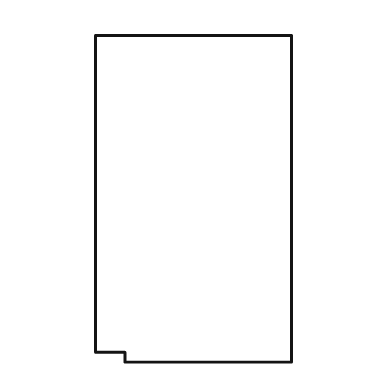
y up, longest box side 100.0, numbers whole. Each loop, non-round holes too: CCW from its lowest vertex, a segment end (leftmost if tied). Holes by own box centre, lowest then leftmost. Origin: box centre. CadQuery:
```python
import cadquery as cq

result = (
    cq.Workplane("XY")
    .moveTo(-21.0, -50.0)
    .lineTo(30.0, -50.0)
    .lineTo(30.0, 50.0)
    .lineTo(-30.0, 50.0)
    .lineTo(-30.0, -47.0)
    .lineTo(-21.0, -47.0)
    .close()
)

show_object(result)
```